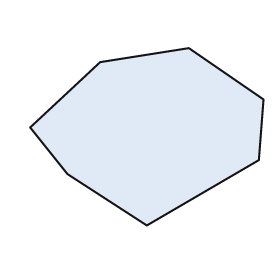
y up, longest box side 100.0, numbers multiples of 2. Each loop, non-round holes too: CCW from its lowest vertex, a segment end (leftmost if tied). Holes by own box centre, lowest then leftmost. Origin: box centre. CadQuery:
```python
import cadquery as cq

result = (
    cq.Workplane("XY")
    .moveTo(0.0, -38.0)
    .lineTo(48.0, -10.0)
    .lineTo(50.0, 16.0)
    .lineTo(18.0, 38.0)
    .lineTo(-20.0, 32.0)
    .lineTo(-50.0, 4.0)
    .lineTo(-34.0, -16.0)
    .close()
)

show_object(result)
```